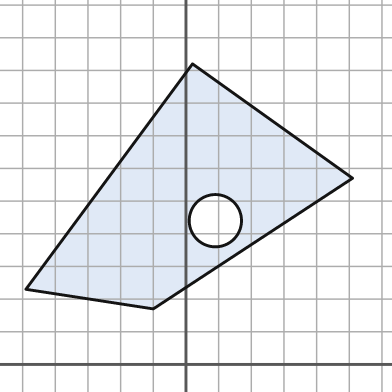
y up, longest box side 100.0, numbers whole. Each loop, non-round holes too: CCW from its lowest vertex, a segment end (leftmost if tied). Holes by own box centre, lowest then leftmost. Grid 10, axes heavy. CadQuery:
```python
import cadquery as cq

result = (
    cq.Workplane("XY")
    .moveTo(-10.0, 17.0)
    .lineTo(51.0, 57.0)
    .lineTo(2.0, 92.0)
    .lineTo(-49.0, 23.0)
    .close()
    .moveTo(9.0, 44.0)
    .circle(8.0)
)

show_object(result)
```